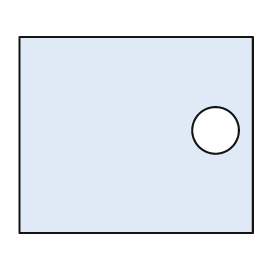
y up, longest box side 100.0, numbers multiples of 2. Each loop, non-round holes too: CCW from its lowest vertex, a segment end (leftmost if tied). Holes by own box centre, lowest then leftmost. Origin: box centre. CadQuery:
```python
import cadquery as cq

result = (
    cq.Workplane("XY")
    .moveTo(-50.0, -42.0)
    .lineTo(50.0, -42.0)
    .lineTo(50.0, 42.0)
    .lineTo(-50.0, 42.0)
    .close()
    .moveTo(34.0, 2.0)
    .circle(10.0)
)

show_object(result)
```